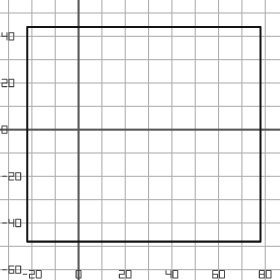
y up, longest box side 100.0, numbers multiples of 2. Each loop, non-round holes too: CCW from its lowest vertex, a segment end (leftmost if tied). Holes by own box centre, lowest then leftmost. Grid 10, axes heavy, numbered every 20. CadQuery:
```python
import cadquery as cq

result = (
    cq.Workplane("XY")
    .moveTo(-22.0, -48.0)
    .lineTo(78.0, -48.0)
    .lineTo(78.0, 44.0)
    .lineTo(-22.0, 44.0)
    .close()
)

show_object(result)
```